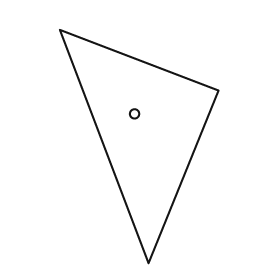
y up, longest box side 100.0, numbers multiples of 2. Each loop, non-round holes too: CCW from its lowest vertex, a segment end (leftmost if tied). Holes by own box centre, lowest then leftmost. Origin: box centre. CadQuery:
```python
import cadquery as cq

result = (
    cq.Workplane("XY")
    .moveTo(4.0, -50.0)
    .lineTo(34.0, 24.0)
    .lineTo(-34.0, 50.0)
    .close()
    .moveTo(-2.0, 14.0)
    .circle(2.0)
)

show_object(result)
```